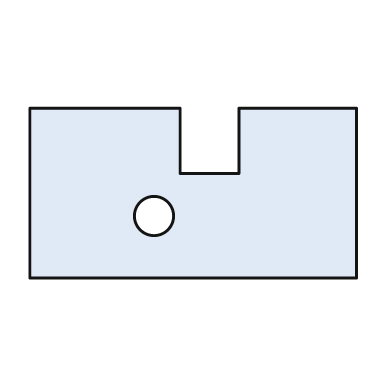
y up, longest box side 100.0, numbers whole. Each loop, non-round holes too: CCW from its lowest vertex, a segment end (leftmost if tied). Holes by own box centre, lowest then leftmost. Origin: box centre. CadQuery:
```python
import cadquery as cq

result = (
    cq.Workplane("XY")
    .moveTo(-50.0, -26.0)
    .lineTo(50.0, -26.0)
    .lineTo(50.0, 26.0)
    .lineTo(14.0, 26.0)
    .lineTo(14.0, 6.0)
    .lineTo(-4.0, 6.0)
    .lineTo(-4.0, 26.0)
    .lineTo(-50.0, 26.0)
    .close()
    .moveTo(-12.0, -7.0)
    .circle(6.0)
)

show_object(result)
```